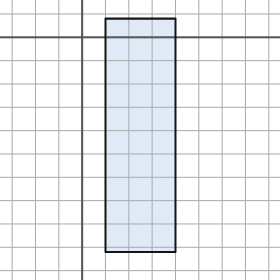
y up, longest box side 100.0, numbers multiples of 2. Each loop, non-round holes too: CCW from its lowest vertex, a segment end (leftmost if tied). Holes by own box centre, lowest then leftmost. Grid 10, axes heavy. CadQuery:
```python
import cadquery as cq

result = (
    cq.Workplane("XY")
    .moveTo(10.0, -92.0)
    .lineTo(40.0, -92.0)
    .lineTo(40.0, 8.0)
    .lineTo(10.0, 8.0)
    .close()
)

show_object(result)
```